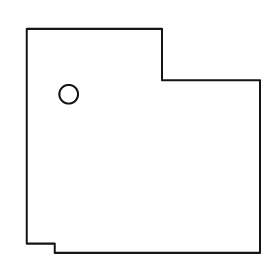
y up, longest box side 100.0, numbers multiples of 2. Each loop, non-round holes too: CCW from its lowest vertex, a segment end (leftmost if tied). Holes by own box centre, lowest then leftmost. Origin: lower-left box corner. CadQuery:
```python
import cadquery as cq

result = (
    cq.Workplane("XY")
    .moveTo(12.0, 0.0)
    .lineTo(100.0, 0.0)
    .lineTo(100.0, 74.0)
    .lineTo(58.0, 74.0)
    .lineTo(58.0, 96.0)
    .lineTo(0.0, 96.0)
    .lineTo(0.0, 4.0)
    .lineTo(12.0, 4.0)
    .close()
    .moveTo(18.0, 68.0)
    .circle(4.0)
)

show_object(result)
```